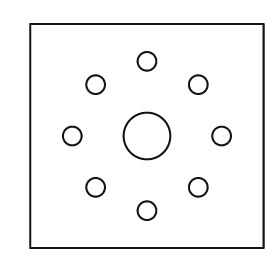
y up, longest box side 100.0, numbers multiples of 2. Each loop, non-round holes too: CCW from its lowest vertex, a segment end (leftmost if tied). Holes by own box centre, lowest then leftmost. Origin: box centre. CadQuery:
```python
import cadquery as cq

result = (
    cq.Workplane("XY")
    .moveTo(-50.0, -48.0)
    .lineTo(50.0, -48.0)
    .lineTo(50.0, 48.0)
    .lineTo(-50.0, 48.0)
    .close()
    .moveTo(0.0, -32.0)
    .circle(4.0)
    .moveTo(-22.0, -22.0)
    .circle(4.0)
    .moveTo(22.0, -22.0)
    .circle(4.0)
    .moveTo(-32.0, 0.0)
    .circle(4.0)
    .moveTo(0.0, 0.0)
    .circle(10.0)
    .moveTo(32.0, 0.0)
    .circle(4.0)
    .moveTo(-22.0, 22.0)
    .circle(4.0)
    .moveTo(22.0, 22.0)
    .circle(4.0)
    .moveTo(0.0, 32.0)
    .circle(4.0)
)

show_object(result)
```